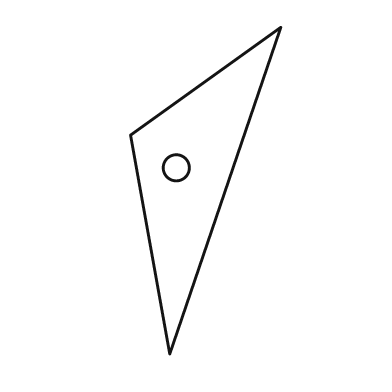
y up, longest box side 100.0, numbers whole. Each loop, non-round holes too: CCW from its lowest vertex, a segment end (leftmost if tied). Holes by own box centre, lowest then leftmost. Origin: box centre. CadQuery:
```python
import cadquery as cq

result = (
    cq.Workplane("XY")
    .moveTo(-11.0, -50.0)
    .lineTo(23.0, 50.0)
    .lineTo(-23.0, 17.0)
    .close()
    .moveTo(-9.0, 7.0)
    .circle(4.0)
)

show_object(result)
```